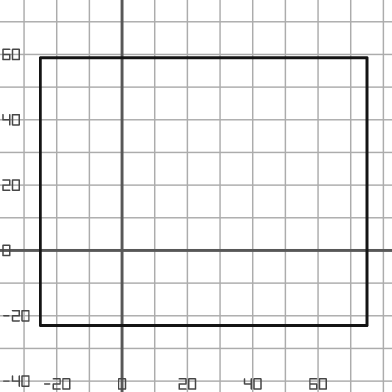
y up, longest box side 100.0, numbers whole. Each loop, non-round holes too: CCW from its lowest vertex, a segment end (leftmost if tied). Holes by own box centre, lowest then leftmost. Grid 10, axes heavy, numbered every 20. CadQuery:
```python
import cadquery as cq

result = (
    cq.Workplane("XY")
    .moveTo(-25.0, -23.0)
    .lineTo(75.0, -23.0)
    .lineTo(75.0, 59.0)
    .lineTo(-25.0, 59.0)
    .close()
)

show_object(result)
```